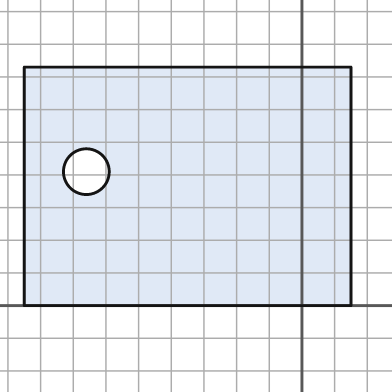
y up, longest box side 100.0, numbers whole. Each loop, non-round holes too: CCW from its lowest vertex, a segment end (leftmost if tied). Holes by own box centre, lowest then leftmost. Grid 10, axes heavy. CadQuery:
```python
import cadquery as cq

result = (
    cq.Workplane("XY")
    .moveTo(-85.0, 0.0)
    .lineTo(15.0, 0.0)
    .lineTo(15.0, 73.0)
    .lineTo(-85.0, 73.0)
    .close()
    .moveTo(-66.0, 41.0)
    .circle(7.0)
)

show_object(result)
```